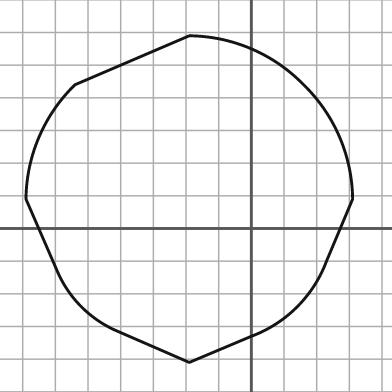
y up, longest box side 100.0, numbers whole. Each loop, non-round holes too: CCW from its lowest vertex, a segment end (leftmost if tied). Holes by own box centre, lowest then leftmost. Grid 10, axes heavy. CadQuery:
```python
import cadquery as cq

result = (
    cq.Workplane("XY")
    .moveTo(-19.0, -41.0)
    .lineTo(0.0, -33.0)
    .threePointArc((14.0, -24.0), (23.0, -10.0))
    .lineTo(31.0, 9.0)
    .threePointArc((27.0, 28.0), (16.0, 44.0))
    .threePointArc((0.0, 55.0), (-19.0, 59.0))
    .lineTo(-54.0, 44.0)
    .threePointArc((-65.0, 28.0), (-69.0, 9.0))
    .lineTo(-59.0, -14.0)
    .threePointArc((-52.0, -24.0), (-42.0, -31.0))
    .close()
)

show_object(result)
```